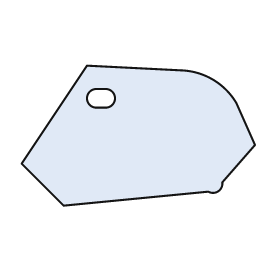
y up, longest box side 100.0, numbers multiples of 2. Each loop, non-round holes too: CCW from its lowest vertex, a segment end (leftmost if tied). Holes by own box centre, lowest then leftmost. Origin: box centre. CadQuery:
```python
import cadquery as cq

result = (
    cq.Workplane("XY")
    .moveTo(-32.0, -30.0)
    .lineTo(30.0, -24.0)
    .threePointArc((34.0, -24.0), (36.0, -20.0))
    .lineTo(50.0, -4.0)
    .lineTo(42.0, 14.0)
    .threePointArc((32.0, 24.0), (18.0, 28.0))
    .lineTo(-22.0, 30.0)
    .lineTo(-50.0, -12.0)
    .close()
    .moveTo(-18.0, 12.0)
    .lineTo(-14.0, 12.0)
    .threePointArc((-10.0, 16.0), (-14.0, 20.0))
    .lineTo(-18.0, 20.0)
    .threePointArc((-22.0, 16.0), (-18.0, 12.0))
    .close()
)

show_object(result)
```